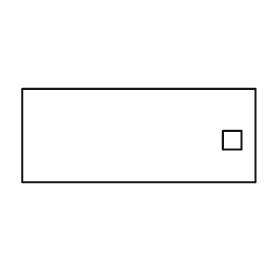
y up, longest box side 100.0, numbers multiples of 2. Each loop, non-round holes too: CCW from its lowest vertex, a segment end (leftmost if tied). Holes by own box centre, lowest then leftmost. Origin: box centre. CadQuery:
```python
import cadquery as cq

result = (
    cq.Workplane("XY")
    .moveTo(-50.0, -20.0)
    .lineTo(50.0, -20.0)
    .lineTo(50.0, 20.0)
    .lineTo(-50.0, 20.0)
    .close()
    .moveTo(36.0, -6.0)
    .lineTo(44.0, -6.0)
    .lineTo(44.0, 2.0)
    .lineTo(36.0, 2.0)
    .close()
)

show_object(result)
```